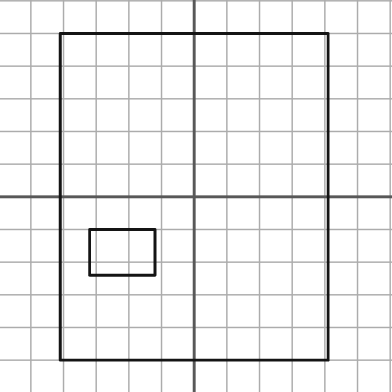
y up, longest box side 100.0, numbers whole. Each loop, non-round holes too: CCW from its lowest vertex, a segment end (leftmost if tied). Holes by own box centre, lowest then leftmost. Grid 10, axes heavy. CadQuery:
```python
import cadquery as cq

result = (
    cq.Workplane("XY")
    .moveTo(-41.0, -50.0)
    .lineTo(41.0, -50.0)
    .lineTo(41.0, 50.0)
    .lineTo(-41.0, 50.0)
    .close()
    .moveTo(-32.0, -24.0)
    .lineTo(-12.0, -24.0)
    .lineTo(-12.0, -10.0)
    .lineTo(-32.0, -10.0)
    .close()
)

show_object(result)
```